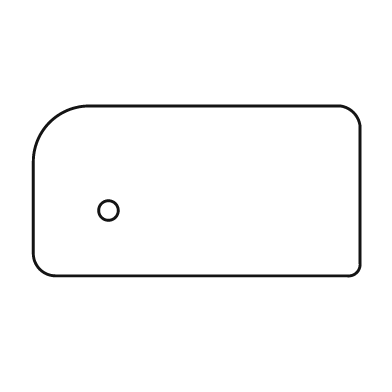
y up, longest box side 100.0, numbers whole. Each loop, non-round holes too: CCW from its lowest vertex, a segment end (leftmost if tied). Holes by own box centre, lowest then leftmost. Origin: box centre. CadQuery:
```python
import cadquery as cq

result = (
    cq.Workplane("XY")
    .moveTo(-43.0, -26.0)
    .lineTo(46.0, -26.0)
    .threePointArc((49.0, -25.0), (50.0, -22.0))
    .lineTo(50.0, 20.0)
    .threePointArc((48.0, 24.0), (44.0, 26.0))
    .lineTo(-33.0, 26.0)
    .threePointArc((-45.0, 21.0), (-50.0, 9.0))
    .lineTo(-50.0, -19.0)
    .threePointArc((-48.0, -24.0), (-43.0, -26.0))
    .close()
    .moveTo(-27.0, -6.0)
    .circle(3.0)
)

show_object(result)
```